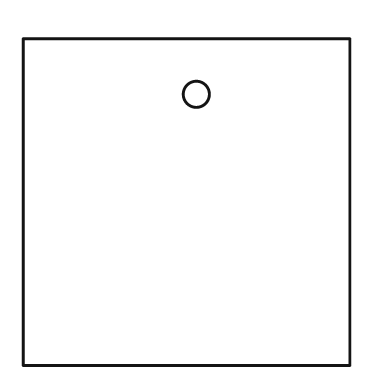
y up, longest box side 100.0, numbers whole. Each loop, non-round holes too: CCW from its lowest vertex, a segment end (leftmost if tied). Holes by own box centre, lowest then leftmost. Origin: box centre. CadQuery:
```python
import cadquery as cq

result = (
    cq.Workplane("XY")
    .moveTo(-50.0, -50.0)
    .lineTo(50.0, -50.0)
    .lineTo(50.0, 50.0)
    .lineTo(-50.0, 50.0)
    .close()
    .moveTo(3.0, 33.0)
    .circle(4.0)
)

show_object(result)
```